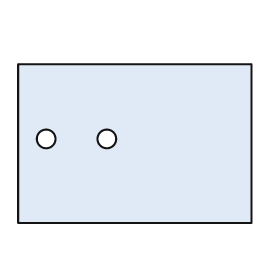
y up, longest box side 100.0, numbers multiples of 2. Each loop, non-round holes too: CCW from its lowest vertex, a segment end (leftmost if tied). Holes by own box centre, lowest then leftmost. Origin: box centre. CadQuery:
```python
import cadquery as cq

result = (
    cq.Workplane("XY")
    .moveTo(-50.0, -34.0)
    .lineTo(50.0, -34.0)
    .lineTo(50.0, 34.0)
    .lineTo(-50.0, 34.0)
    .close()
    .moveTo(-38.0, 2.0)
    .circle(4.0)
    .moveTo(-12.0, 2.0)
    .circle(4.0)
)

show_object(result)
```